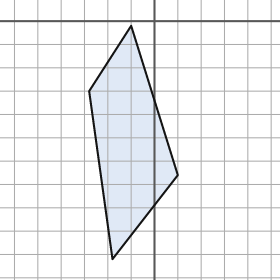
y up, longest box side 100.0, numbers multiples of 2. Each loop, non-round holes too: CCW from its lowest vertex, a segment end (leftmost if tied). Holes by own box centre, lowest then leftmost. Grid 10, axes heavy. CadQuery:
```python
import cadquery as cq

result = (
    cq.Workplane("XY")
    .moveTo(-18.0, -102.0)
    .lineTo(10.0, -66.0)
    .lineTo(-10.0, -2.0)
    .lineTo(-28.0, -30.0)
    .close()
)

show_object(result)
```